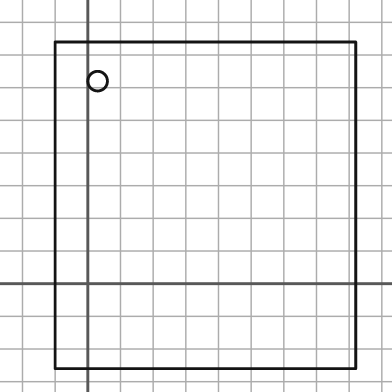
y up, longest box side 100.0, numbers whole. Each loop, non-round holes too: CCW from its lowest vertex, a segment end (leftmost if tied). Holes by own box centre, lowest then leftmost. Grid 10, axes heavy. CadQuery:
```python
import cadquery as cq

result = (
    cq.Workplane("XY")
    .moveTo(-10.0, -26.0)
    .lineTo(82.0, -26.0)
    .lineTo(82.0, 74.0)
    .lineTo(-10.0, 74.0)
    .close()
    .moveTo(3.0, 62.0)
    .circle(3.0)
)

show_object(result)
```